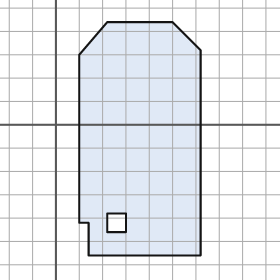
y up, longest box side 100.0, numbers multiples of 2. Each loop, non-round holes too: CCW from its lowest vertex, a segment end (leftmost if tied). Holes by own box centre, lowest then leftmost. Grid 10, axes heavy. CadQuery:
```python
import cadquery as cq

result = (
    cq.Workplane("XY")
    .moveTo(14.0, -56.0)
    .lineTo(62.0, -56.0)
    .lineTo(62.0, 32.0)
    .lineTo(50.0, 44.0)
    .lineTo(22.0, 44.0)
    .lineTo(10.0, 30.0)
    .lineTo(10.0, -42.0)
    .lineTo(14.0, -42.0)
    .close()
    .moveTo(22.0, -46.0)
    .lineTo(30.0, -46.0)
    .lineTo(30.0, -38.0)
    .lineTo(22.0, -38.0)
    .close()
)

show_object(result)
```